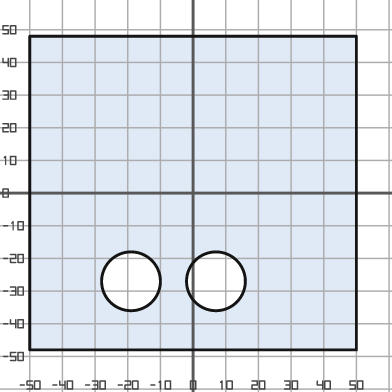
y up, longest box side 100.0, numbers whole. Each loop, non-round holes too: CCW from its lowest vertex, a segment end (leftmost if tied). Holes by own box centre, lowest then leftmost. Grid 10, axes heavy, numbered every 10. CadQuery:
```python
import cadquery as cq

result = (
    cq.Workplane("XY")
    .moveTo(-50.0, -48.0)
    .lineTo(50.0, -48.0)
    .lineTo(50.0, 48.0)
    .lineTo(-50.0, 48.0)
    .close()
    .moveTo(-19.0, -27.0)
    .circle(9.0)
    .moveTo(7.0, -27.0)
    .circle(9.0)
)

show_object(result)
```